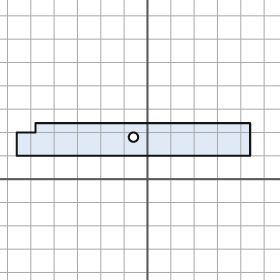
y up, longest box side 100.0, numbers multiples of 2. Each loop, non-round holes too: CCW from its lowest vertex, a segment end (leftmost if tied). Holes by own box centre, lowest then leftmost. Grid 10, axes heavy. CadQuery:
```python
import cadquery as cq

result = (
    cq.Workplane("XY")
    .moveTo(-56.0, 10.0)
    .lineTo(44.0, 10.0)
    .lineTo(44.0, 24.0)
    .lineTo(-48.0, 24.0)
    .lineTo(-48.0, 20.0)
    .lineTo(-56.0, 20.0)
    .close()
    .moveTo(-6.0, 18.0)
    .circle(2.0)
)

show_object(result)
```